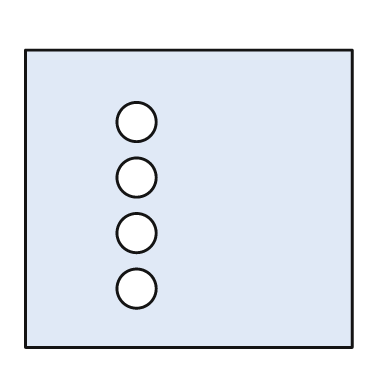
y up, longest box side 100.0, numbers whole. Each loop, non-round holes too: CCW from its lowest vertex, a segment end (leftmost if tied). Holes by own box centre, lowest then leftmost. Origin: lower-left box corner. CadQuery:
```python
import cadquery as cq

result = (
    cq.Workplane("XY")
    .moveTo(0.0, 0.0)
    .lineTo(100.0, 0.0)
    .lineTo(100.0, 91.0)
    .lineTo(0.0, 91.0)
    .close()
    .moveTo(34.0, 18.0)
    .circle(6.0)
    .moveTo(34.0, 35.0)
    .circle(6.0)
    .moveTo(34.0, 52.0)
    .circle(6.0)
    .moveTo(34.0, 69.0)
    .circle(6.0)
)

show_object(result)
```